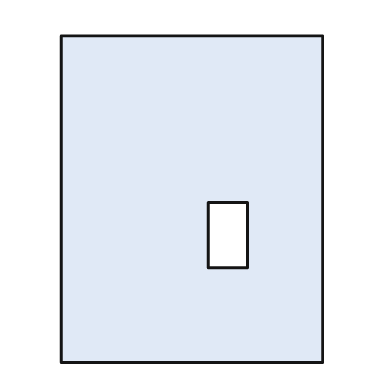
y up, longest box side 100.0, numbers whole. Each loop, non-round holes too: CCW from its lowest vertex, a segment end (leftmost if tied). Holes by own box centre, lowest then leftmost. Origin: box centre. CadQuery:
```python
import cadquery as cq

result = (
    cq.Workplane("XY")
    .moveTo(-40.0, -50.0)
    .lineTo(40.0, -50.0)
    .lineTo(40.0, 50.0)
    .lineTo(-40.0, 50.0)
    .close()
    .moveTo(5.0, -21.0)
    .lineTo(17.0, -21.0)
    .lineTo(17.0, -1.0)
    .lineTo(5.0, -1.0)
    .close()
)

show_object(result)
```